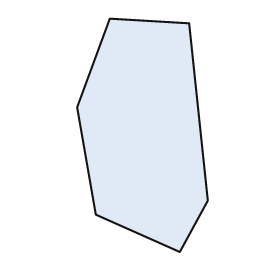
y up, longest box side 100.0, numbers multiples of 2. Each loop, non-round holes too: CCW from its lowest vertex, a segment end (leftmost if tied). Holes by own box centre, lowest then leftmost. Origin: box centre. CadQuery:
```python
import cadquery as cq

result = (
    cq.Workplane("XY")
    .moveTo(16.0, -50.0)
    .lineTo(28.0, -28.0)
    .lineTo(20.0, 48.0)
    .lineTo(-14.0, 50.0)
    .lineTo(-28.0, 12.0)
    .lineTo(-20.0, -34.0)
    .close()
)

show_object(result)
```